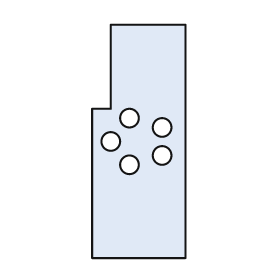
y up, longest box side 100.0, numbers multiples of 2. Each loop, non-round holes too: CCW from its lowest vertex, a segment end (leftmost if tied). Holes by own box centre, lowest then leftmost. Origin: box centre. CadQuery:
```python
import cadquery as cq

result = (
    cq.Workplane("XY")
    .moveTo(-20.0, -50.0)
    .lineTo(20.0, -50.0)
    .lineTo(20.0, 50.0)
    .lineTo(-12.0, 50.0)
    .lineTo(-12.0, 14.0)
    .lineTo(-20.0, 14.0)
    .close()
    .moveTo(-4.0, -10.0)
    .circle(4.0)
    .moveTo(10.0, -6.0)
    .circle(4.0)
    .moveTo(-12.0, 0.0)
    .circle(4.0)
    .moveTo(10.0, 6.0)
    .circle(4.0)
    .moveTo(-4.0, 10.0)
    .circle(4.0)
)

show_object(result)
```